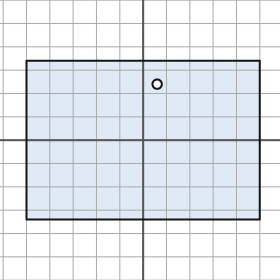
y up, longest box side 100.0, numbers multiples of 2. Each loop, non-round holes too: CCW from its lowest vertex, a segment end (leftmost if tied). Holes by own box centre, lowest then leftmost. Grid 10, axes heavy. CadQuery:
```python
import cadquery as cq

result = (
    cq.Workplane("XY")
    .moveTo(-50.0, -34.0)
    .lineTo(50.0, -34.0)
    .lineTo(50.0, 34.0)
    .lineTo(-50.0, 34.0)
    .close()
    .moveTo(6.0, 24.0)
    .circle(2.0)
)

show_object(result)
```